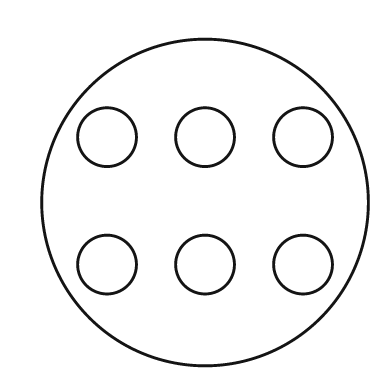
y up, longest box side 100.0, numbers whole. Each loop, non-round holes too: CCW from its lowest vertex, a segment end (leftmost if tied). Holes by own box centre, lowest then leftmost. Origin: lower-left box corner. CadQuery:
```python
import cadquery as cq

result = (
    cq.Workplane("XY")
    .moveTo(50.0, 50.0)
    .circle(50.0)
    .moveTo(20.0, 31.0)
    .circle(9.0)
    .moveTo(50.0, 31.0)
    .circle(9.0)
    .moveTo(80.0, 31.0)
    .circle(9.0)
    .moveTo(20.0, 70.0)
    .circle(9.0)
    .moveTo(50.0, 70.0)
    .circle(9.0)
    .moveTo(80.0, 70.0)
    .circle(9.0)
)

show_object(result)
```